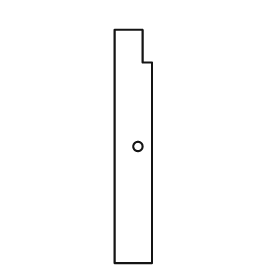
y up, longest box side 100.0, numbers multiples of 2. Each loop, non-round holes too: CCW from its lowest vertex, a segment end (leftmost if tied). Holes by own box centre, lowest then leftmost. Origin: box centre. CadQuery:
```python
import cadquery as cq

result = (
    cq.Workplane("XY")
    .moveTo(-8.0, -50.0)
    .lineTo(8.0, -50.0)
    .lineTo(8.0, 36.0)
    .lineTo(4.0, 36.0)
    .lineTo(4.0, 50.0)
    .lineTo(-8.0, 50.0)
    .close()
    .moveTo(2.0, 0.0)
    .circle(2.0)
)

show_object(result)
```